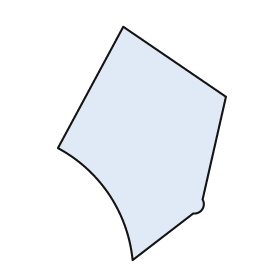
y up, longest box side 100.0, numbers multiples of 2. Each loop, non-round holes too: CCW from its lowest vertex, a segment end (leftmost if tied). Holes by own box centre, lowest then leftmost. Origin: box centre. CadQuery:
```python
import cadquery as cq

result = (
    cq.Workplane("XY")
    .moveTo(-4.0, -50.0)
    .lineTo(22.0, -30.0)
    .threePointArc((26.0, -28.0), (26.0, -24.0))
    .lineTo(36.0, 20.0)
    .lineTo(-8.0, 50.0)
    .lineTo(-36.0, -2.0)
    .threePointArc((-14.0, -22.0), (-4.0, -50.0))
    .close()
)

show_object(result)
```